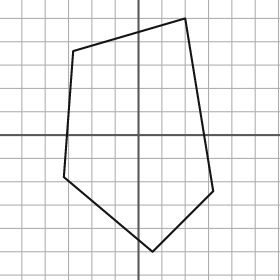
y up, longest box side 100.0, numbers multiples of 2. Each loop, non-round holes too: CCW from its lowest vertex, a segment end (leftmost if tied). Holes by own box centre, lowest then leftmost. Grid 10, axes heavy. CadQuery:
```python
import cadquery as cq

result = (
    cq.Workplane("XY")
    .moveTo(6.0, -50.0)
    .lineTo(32.0, -24.0)
    .lineTo(20.0, 50.0)
    .lineTo(-28.0, 36.0)
    .lineTo(-32.0, -18.0)
    .close()
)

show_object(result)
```